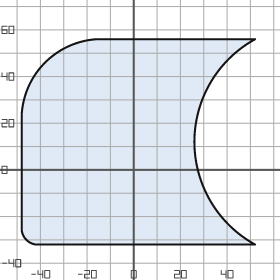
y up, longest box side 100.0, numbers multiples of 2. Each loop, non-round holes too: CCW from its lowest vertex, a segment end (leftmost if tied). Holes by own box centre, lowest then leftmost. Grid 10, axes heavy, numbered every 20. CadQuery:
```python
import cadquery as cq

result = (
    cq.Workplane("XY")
    .moveTo(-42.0, -32.0)
    .lineTo(52.0, -32.0)
    .threePointArc((26.0, 12.0), (52.0, 56.0))
    .lineTo(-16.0, 56.0)
    .threePointArc((-38.0, 46.0), (-48.0, 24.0))
    .lineTo(-48.0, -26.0)
    .threePointArc((-46.0, -30.0), (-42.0, -32.0))
    .close()
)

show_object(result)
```